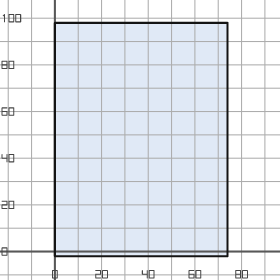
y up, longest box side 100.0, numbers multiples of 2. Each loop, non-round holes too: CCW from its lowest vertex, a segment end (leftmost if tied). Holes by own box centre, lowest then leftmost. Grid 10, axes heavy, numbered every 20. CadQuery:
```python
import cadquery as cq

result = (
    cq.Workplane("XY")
    .moveTo(0.0, -2.0)
    .lineTo(74.0, -2.0)
    .lineTo(74.0, 98.0)
    .lineTo(0.0, 98.0)
    .close()
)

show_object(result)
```